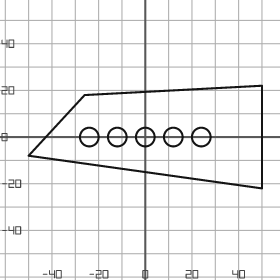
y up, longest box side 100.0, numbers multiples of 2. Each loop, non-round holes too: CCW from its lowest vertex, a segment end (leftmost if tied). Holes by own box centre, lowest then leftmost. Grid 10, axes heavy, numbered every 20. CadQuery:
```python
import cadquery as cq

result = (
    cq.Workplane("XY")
    .moveTo(50.0, -22.0)
    .lineTo(50.0, 22.0)
    .lineTo(-26.0, 18.0)
    .lineTo(-50.0, -8.0)
    .close()
    .moveTo(-24.0, 0.0)
    .circle(4.0)
    .moveTo(-12.0, 0.0)
    .circle(4.0)
    .moveTo(0.0, 0.0)
    .circle(4.0)
    .moveTo(12.0, 0.0)
    .circle(4.0)
    .moveTo(24.0, 0.0)
    .circle(4.0)
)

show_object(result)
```